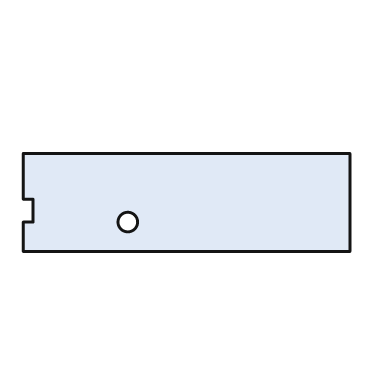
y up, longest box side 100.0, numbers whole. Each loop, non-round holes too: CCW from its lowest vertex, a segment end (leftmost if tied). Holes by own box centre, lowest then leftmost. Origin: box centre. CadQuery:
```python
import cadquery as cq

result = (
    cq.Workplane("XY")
    .moveTo(-50.0, -15.0)
    .lineTo(50.0, -15.0)
    .lineTo(50.0, 15.0)
    .lineTo(-50.0, 15.0)
    .lineTo(-50.0, 1.0)
    .lineTo(-47.0, 1.0)
    .lineTo(-47.0, -6.0)
    .lineTo(-50.0, -6.0)
    .close()
    .moveTo(-18.0, -6.0)
    .circle(3.0)
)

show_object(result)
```